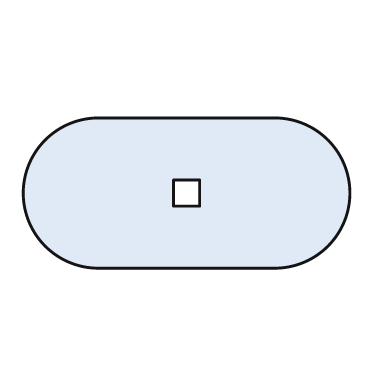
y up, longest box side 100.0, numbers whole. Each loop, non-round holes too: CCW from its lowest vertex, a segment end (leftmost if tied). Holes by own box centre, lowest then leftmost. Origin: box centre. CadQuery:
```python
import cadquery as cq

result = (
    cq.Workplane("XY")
    .moveTo(-27.0, -23.0)
    .lineTo(27.0, -23.0)
    .threePointArc((50.0, 0.0), (27.0, 23.0))
    .lineTo(-27.0, 23.0)
    .threePointArc((-50.0, 0.0), (-27.0, -23.0))
    .close()
    .moveTo(-4.0, -4.0)
    .lineTo(4.0, -4.0)
    .lineTo(4.0, 4.0)
    .lineTo(-4.0, 4.0)
    .close()
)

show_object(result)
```